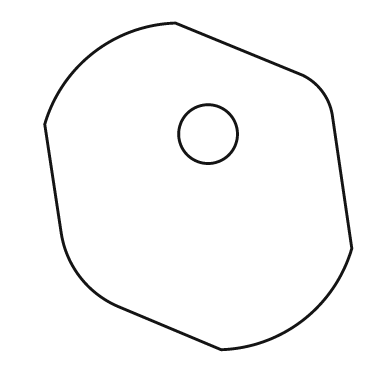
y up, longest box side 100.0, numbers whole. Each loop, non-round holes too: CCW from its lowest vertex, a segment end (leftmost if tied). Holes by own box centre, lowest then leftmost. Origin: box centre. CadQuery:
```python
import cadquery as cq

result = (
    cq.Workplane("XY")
    .moveTo(7.0, -50.0)
    .threePointArc((32.0, -41.0), (47.0, -19.0))
    .lineTo(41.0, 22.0)
    .threePointArc((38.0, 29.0), (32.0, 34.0))
    .lineTo(-7.0, 50.0)
    .threePointArc((-32.0, 41.0), (-47.0, 19.0))
    .lineTo(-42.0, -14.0)
    .threePointArc((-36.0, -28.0), (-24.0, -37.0))
    .close()
    .moveTo(3.0, 16.0)
    .circle(9.0)
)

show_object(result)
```